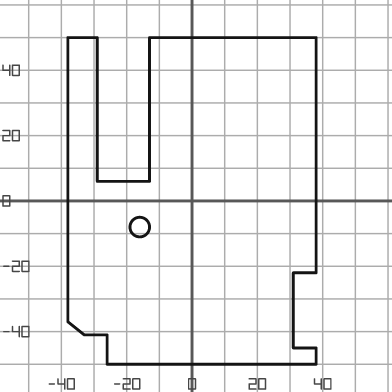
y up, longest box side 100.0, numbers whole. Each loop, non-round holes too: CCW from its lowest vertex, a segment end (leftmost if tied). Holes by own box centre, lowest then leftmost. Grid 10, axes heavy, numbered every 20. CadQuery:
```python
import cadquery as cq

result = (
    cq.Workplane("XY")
    .moveTo(-26.0, -50.0)
    .lineTo(38.0, -50.0)
    .lineTo(38.0, -45.0)
    .lineTo(31.0, -45.0)
    .lineTo(31.0, -22.0)
    .lineTo(38.0, -22.0)
    .lineTo(38.0, 50.0)
    .lineTo(-13.0, 50.0)
    .lineTo(-13.0, 6.0)
    .lineTo(-29.0, 6.0)
    .lineTo(-29.0, 50.0)
    .lineTo(-38.0, 50.0)
    .lineTo(-38.0, -37.0)
    .lineTo(-33.0, -41.0)
    .lineTo(-26.0, -41.0)
    .close()
    .moveTo(-16.0, -8.0)
    .circle(3.0)
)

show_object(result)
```